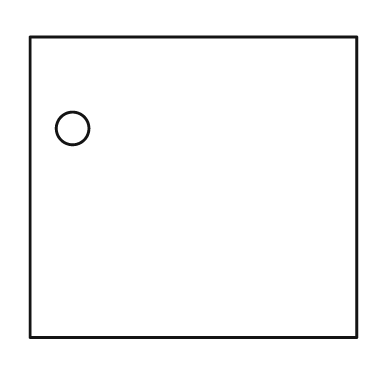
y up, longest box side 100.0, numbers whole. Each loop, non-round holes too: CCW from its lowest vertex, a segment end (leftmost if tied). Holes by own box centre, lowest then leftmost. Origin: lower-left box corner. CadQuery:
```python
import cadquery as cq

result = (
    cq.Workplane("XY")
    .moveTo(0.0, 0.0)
    .lineTo(100.0, 0.0)
    .lineTo(100.0, 92.0)
    .lineTo(0.0, 92.0)
    .close()
    .moveTo(13.0, 64.0)
    .circle(5.0)
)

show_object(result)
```